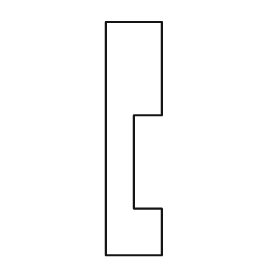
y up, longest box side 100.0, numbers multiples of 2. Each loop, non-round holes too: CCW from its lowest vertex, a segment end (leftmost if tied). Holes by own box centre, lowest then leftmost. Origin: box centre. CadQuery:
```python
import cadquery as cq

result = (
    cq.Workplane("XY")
    .moveTo(-12.0, -50.0)
    .lineTo(12.0, -50.0)
    .lineTo(12.0, -30.0)
    .lineTo(0.0, -30.0)
    .lineTo(0.0, 10.0)
    .lineTo(12.0, 10.0)
    .lineTo(12.0, 50.0)
    .lineTo(-12.0, 50.0)
    .close()
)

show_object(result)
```